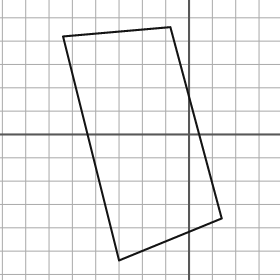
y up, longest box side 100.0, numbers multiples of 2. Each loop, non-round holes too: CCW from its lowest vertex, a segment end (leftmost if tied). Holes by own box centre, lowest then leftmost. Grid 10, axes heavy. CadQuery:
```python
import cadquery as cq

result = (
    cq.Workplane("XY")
    .moveTo(-30.0, -54.0)
    .lineTo(14.0, -36.0)
    .lineTo(-8.0, 46.0)
    .lineTo(-54.0, 42.0)
    .close()
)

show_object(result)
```